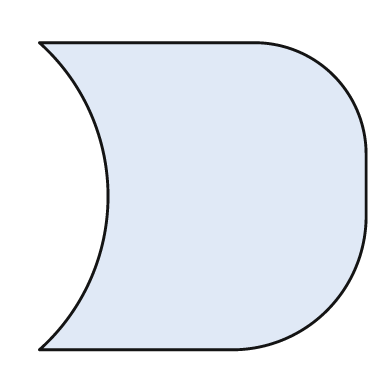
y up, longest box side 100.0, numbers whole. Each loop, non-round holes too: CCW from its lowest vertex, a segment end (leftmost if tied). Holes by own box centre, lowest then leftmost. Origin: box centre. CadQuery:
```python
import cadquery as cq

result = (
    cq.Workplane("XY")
    .moveTo(-50.0, -47.0)
    .lineTo(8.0, -47.0)
    .threePointArc((38.0, -35.0), (50.0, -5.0))
    .lineTo(50.0, 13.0)
    .threePointArc((40.0, 37.0), (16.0, 47.0))
    .lineTo(-50.0, 47.0)
    .threePointArc((-29.0, 0.0), (-50.0, -47.0))
    .close()
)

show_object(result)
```